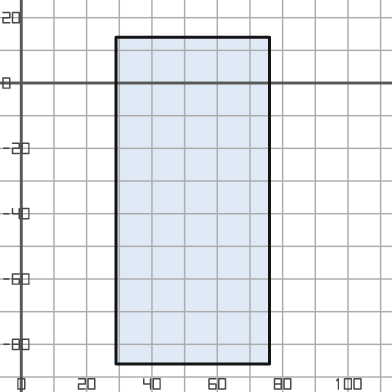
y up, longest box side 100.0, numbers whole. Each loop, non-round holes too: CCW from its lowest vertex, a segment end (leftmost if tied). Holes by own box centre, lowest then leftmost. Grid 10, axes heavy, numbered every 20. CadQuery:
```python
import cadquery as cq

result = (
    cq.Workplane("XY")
    .moveTo(29.0, -86.0)
    .lineTo(76.0, -86.0)
    .lineTo(76.0, 14.0)
    .lineTo(29.0, 14.0)
    .close()
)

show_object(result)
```